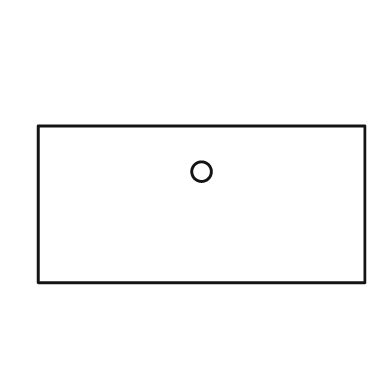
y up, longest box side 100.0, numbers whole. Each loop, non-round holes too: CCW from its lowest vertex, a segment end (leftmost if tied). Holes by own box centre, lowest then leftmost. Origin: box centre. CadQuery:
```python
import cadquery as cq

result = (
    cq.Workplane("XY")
    .moveTo(-50.0, -24.0)
    .lineTo(50.0, -24.0)
    .lineTo(50.0, 24.0)
    .lineTo(-50.0, 24.0)
    .close()
    .moveTo(0.0, 10.0)
    .circle(3.0)
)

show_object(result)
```